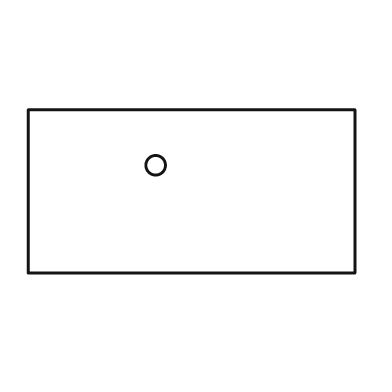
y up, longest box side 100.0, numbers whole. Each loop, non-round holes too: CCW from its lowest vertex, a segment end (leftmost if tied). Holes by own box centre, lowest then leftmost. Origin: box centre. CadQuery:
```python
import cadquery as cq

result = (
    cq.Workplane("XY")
    .moveTo(-50.0, -25.0)
    .lineTo(50.0, -25.0)
    .lineTo(50.0, 25.0)
    .lineTo(-50.0, 25.0)
    .close()
    .moveTo(-11.0, 8.0)
    .circle(3.0)
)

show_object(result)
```